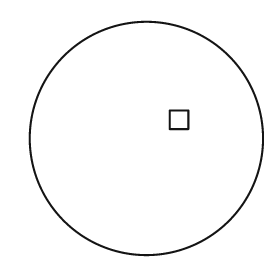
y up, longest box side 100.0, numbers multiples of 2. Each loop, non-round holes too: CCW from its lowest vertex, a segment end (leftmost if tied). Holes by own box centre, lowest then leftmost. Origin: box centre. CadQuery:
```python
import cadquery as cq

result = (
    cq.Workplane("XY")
    .moveTo(0.0, 0.0)
    .circle(50.0)
    .moveTo(10.0, 4.0)
    .lineTo(18.0, 4.0)
    .lineTo(18.0, 12.0)
    .lineTo(10.0, 12.0)
    .close()
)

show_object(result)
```